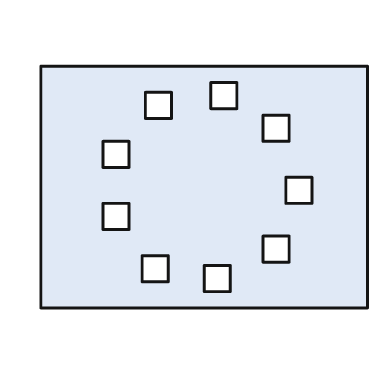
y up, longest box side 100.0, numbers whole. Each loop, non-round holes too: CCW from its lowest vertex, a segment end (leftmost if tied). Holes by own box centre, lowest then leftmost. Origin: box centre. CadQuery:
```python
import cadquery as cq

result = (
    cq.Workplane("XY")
    .moveTo(-50.0, -37.0)
    .lineTo(50.0, -37.0)
    .lineTo(50.0, 37.0)
    .lineTo(-50.0, 37.0)
    .close()
    .moveTo(0.0, -32.0)
    .lineTo(8.0, -32.0)
    .lineTo(8.0, -24.0)
    .lineTo(0.0, -24.0)
    .close()
    .moveTo(-19.0, -29.0)
    .lineTo(-11.0, -29.0)
    .lineTo(-11.0, -21.0)
    .lineTo(-19.0, -21.0)
    .close()
    .moveTo(18.0, -23.0)
    .lineTo(26.0, -23.0)
    .lineTo(26.0, -15.0)
    .lineTo(18.0, -15.0)
    .close()
    .moveTo(-31.0, -13.0)
    .lineTo(-23.0, -13.0)
    .lineTo(-23.0, -5.0)
    .lineTo(-31.0, -5.0)
    .close()
    .moveTo(25.0, -5.0)
    .lineTo(33.0, -5.0)
    .lineTo(33.0, 3.0)
    .lineTo(25.0, 3.0)
    .close()
    .moveTo(-31.0, 6.0)
    .lineTo(-23.0, 6.0)
    .lineTo(-23.0, 14.0)
    .lineTo(-31.0, 14.0)
    .close()
    .moveTo(18.0, 14.0)
    .lineTo(26.0, 14.0)
    .lineTo(26.0, 22.0)
    .lineTo(18.0, 22.0)
    .close()
    .moveTo(-18.0, 21.0)
    .lineTo(-10.0, 21.0)
    .lineTo(-10.0, 29.0)
    .lineTo(-18.0, 29.0)
    .close()
    .moveTo(2.0, 24.0)
    .lineTo(10.0, 24.0)
    .lineTo(10.0, 32.0)
    .lineTo(2.0, 32.0)
    .close()
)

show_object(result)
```